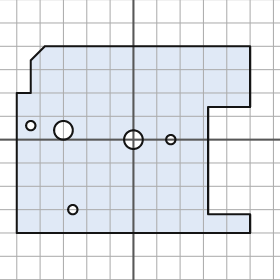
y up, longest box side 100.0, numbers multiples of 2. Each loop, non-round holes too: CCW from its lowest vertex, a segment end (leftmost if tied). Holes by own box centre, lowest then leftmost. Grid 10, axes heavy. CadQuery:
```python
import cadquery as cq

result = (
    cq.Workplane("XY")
    .moveTo(-50.0, -40.0)
    .lineTo(50.0, -40.0)
    .lineTo(50.0, -32.0)
    .lineTo(32.0, -32.0)
    .lineTo(32.0, 14.0)
    .lineTo(50.0, 14.0)
    .lineTo(50.0, 40.0)
    .lineTo(-38.0, 40.0)
    .lineTo(-44.0, 34.0)
    .lineTo(-44.0, 20.0)
    .lineTo(-50.0, 20.0)
    .close()
    .moveTo(-26.0, -30.0)
    .circle(2.0)
    .moveTo(0.0, 0.0)
    .circle(4.0)
    .moveTo(16.0, 0.0)
    .circle(2.0)
    .moveTo(-30.0, 4.0)
    .circle(4.0)
    .moveTo(-44.0, 6.0)
    .circle(2.0)
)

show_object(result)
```